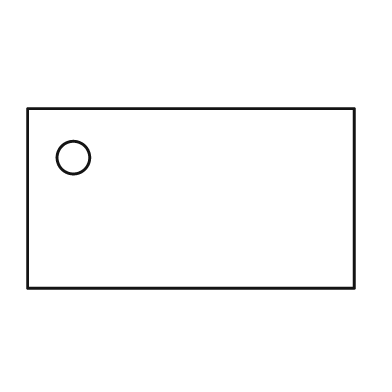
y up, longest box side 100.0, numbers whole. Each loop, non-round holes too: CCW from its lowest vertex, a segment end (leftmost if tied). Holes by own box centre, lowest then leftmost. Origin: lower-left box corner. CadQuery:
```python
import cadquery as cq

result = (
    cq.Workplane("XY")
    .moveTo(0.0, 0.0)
    .lineTo(100.0, 0.0)
    .lineTo(100.0, 55.0)
    .lineTo(0.0, 55.0)
    .close()
    .moveTo(14.0, 40.0)
    .circle(5.0)
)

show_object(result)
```